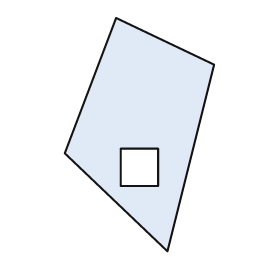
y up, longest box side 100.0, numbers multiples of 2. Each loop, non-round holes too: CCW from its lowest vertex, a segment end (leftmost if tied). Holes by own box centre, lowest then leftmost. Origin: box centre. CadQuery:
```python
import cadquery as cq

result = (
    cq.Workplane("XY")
    .moveTo(12.0, -50.0)
    .lineTo(32.0, 30.0)
    .lineTo(-10.0, 50.0)
    .lineTo(-32.0, -8.0)
    .close()
    .moveTo(-8.0, -22.0)
    .lineTo(8.0, -22.0)
    .lineTo(8.0, -6.0)
    .lineTo(-8.0, -6.0)
    .close()
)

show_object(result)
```